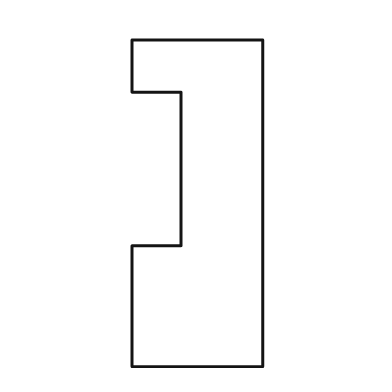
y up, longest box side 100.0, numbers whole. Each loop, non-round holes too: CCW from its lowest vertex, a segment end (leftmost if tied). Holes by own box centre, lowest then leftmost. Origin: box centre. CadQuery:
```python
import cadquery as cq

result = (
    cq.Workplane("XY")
    .moveTo(-20.0, -50.0)
    .lineTo(20.0, -50.0)
    .lineTo(20.0, 50.0)
    .lineTo(-20.0, 50.0)
    .lineTo(-20.0, 34.0)
    .lineTo(-5.0, 34.0)
    .lineTo(-5.0, -13.0)
    .lineTo(-20.0, -13.0)
    .close()
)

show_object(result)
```